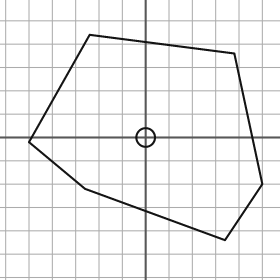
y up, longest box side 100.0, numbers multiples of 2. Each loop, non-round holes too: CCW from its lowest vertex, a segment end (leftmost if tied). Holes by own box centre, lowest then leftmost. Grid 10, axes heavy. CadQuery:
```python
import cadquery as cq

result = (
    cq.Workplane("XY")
    .moveTo(34.0, -44.0)
    .lineTo(50.0, -20.0)
    .lineTo(38.0, 36.0)
    .lineTo(-24.0, 44.0)
    .lineTo(-50.0, -2.0)
    .lineTo(-26.0, -22.0)
    .close()
    .moveTo(0.0, 0.0)
    .circle(4.0)
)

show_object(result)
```